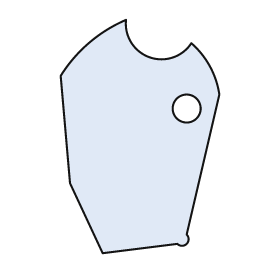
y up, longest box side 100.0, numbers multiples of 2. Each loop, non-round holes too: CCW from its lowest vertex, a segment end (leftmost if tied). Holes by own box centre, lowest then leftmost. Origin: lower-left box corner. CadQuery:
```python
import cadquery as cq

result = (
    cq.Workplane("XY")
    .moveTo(18.0, 0.0)
    .lineTo(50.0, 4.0)
    .threePointArc((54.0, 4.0), (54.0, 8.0))
    .lineTo(68.0, 68.0)
    .threePointArc((64.0, 80.0), (56.0, 90.0))
    .threePointArc((38.0, 84.0), (28.0, 100.0))
    .threePointArc((12.0, 90.0), (0.0, 76.0))
    .lineTo(4.0, 30.0)
    .close()
    .moveTo(54.0, 62.0)
    .circle(6.0)
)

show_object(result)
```